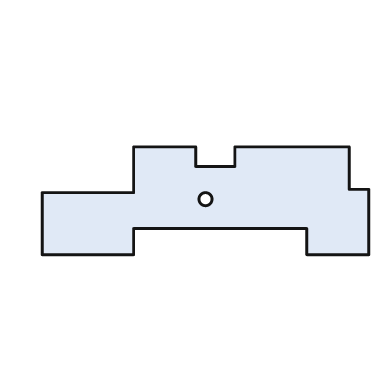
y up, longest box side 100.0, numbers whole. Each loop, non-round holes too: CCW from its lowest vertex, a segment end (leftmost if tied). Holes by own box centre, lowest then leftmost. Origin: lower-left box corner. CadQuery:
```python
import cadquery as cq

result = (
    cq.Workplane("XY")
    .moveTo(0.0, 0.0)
    .lineTo(28.0, 0.0)
    .lineTo(28.0, 8.0)
    .lineTo(81.0, 8.0)
    .lineTo(81.0, 0.0)
    .lineTo(100.0, 0.0)
    .lineTo(100.0, 20.0)
    .lineTo(94.0, 20.0)
    .lineTo(94.0, 33.0)
    .lineTo(59.0, 33.0)
    .lineTo(59.0, 27.0)
    .lineTo(47.0, 27.0)
    .lineTo(47.0, 33.0)
    .lineTo(28.0, 33.0)
    .lineTo(28.0, 19.0)
    .lineTo(0.0, 19.0)
    .close()
    .moveTo(50.0, 17.0)
    .circle(2.0)
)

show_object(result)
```